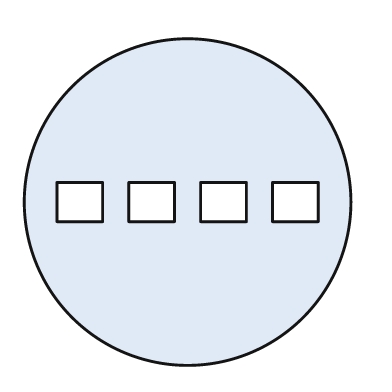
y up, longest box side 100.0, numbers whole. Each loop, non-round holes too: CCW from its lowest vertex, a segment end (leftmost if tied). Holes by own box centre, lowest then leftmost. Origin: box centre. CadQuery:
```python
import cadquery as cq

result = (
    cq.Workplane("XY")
    .moveTo(0.0, 0.0)
    .circle(50.0)
    .moveTo(-40.0, -6.0)
    .lineTo(-26.0, -6.0)
    .lineTo(-26.0, 6.0)
    .lineTo(-40.0, 6.0)
    .close()
    .moveTo(-18.0, -6.0)
    .lineTo(-4.0, -6.0)
    .lineTo(-4.0, 6.0)
    .lineTo(-18.0, 6.0)
    .close()
    .moveTo(4.0, -6.0)
    .lineTo(18.0, -6.0)
    .lineTo(18.0, 6.0)
    .lineTo(4.0, 6.0)
    .close()
    .moveTo(26.0, -6.0)
    .lineTo(40.0, -6.0)
    .lineTo(40.0, 6.0)
    .lineTo(26.0, 6.0)
    .close()
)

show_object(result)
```